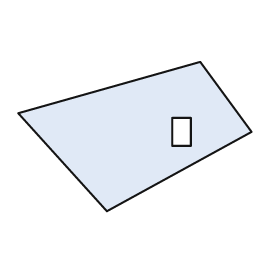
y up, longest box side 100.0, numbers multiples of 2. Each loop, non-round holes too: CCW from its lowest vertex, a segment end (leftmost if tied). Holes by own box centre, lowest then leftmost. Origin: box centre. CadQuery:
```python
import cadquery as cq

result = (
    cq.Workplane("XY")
    .moveTo(-12.0, -32.0)
    .lineTo(50.0, 2.0)
    .lineTo(28.0, 32.0)
    .lineTo(-50.0, 10.0)
    .close()
    .moveTo(16.0, -4.0)
    .lineTo(24.0, -4.0)
    .lineTo(24.0, 8.0)
    .lineTo(16.0, 8.0)
    .close()
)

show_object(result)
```